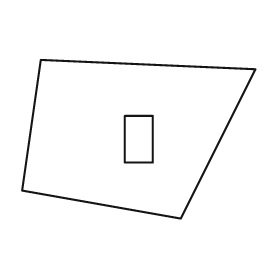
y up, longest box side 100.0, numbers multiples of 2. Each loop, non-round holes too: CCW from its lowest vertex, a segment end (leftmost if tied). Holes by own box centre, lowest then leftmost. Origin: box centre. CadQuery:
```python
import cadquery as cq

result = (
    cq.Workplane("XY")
    .moveTo(18.0, -34.0)
    .lineTo(50.0, 30.0)
    .lineTo(-42.0, 34.0)
    .lineTo(-50.0, -22.0)
    .close()
    .moveTo(-6.0, -10.0)
    .lineTo(6.0, -10.0)
    .lineTo(6.0, 10.0)
    .lineTo(-6.0, 10.0)
    .close()
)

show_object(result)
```